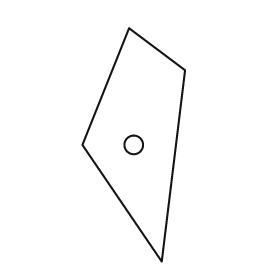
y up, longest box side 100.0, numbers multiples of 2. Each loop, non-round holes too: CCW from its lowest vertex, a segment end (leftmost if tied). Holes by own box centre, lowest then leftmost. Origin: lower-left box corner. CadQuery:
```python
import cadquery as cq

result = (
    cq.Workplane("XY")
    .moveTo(34.0, 0.0)
    .lineTo(44.0, 82.0)
    .lineTo(20.0, 100.0)
    .lineTo(0.0, 50.0)
    .close()
    .moveTo(22.0, 50.0)
    .circle(4.0)
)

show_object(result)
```